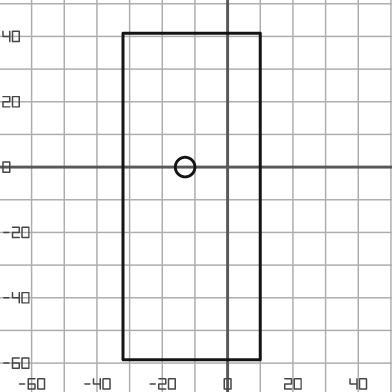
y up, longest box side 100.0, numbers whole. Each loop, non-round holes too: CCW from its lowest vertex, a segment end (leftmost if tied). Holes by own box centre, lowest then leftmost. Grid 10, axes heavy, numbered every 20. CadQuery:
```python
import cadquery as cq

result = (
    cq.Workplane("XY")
    .moveTo(-32.0, -59.0)
    .lineTo(10.0, -59.0)
    .lineTo(10.0, 41.0)
    .lineTo(-32.0, 41.0)
    .close()
    .moveTo(-13.0, 0.0)
    .circle(3.0)
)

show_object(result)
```